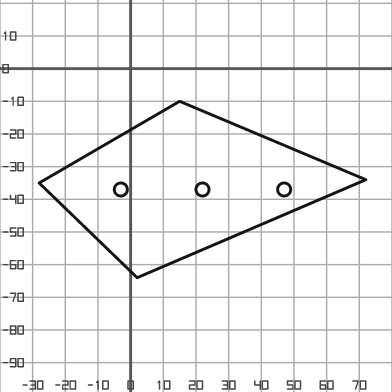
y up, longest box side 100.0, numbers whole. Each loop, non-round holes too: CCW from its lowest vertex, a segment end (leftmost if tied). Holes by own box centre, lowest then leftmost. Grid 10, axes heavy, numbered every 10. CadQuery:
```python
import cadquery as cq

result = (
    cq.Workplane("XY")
    .moveTo(2.0, -64.0)
    .lineTo(72.0, -34.0)
    .lineTo(15.0, -10.0)
    .lineTo(-28.0, -35.0)
    .close()
    .moveTo(-3.0, -37.0)
    .circle(2.0)
    .moveTo(22.0, -37.0)
    .circle(2.0)
    .moveTo(47.0, -37.0)
    .circle(2.0)
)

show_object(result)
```